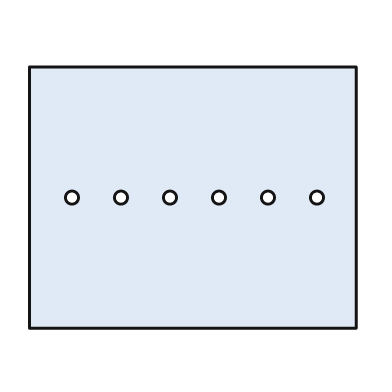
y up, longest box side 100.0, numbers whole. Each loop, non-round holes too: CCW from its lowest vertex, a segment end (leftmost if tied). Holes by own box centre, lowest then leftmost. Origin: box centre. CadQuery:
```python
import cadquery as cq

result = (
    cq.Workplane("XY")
    .moveTo(-50.0, -40.0)
    .lineTo(50.0, -40.0)
    .lineTo(50.0, 40.0)
    .lineTo(-50.0, 40.0)
    .close()
    .moveTo(-37.0, 0.0)
    .circle(2.0)
    .moveTo(-22.0, 0.0)
    .circle(2.0)
    .moveTo(-7.0, 0.0)
    .circle(2.0)
    .moveTo(8.0, 0.0)
    .circle(2.0)
    .moveTo(23.0, 0.0)
    .circle(2.0)
    .moveTo(38.0, 0.0)
    .circle(2.0)
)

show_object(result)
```